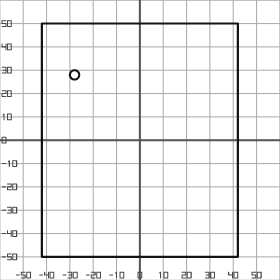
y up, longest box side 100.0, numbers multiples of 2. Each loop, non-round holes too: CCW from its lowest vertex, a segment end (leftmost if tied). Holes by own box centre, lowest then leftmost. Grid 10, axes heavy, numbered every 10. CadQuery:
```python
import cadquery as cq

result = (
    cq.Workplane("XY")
    .moveTo(-42.0, -50.0)
    .lineTo(42.0, -50.0)
    .lineTo(42.0, 50.0)
    .lineTo(-42.0, 50.0)
    .close()
    .moveTo(-28.0, 28.0)
    .circle(2.0)
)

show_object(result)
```